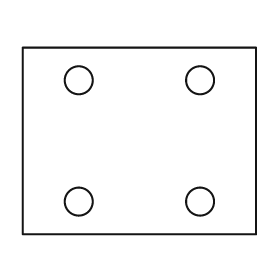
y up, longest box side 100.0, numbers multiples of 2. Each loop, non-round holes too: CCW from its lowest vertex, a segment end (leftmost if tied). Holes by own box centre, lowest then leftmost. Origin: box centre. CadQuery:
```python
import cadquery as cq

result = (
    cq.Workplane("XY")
    .moveTo(-50.0, -40.0)
    .lineTo(50.0, -40.0)
    .lineTo(50.0, 40.0)
    .lineTo(-50.0, 40.0)
    .close()
    .moveTo(-26.0, -26.0)
    .circle(6.0)
    .moveTo(26.0, -26.0)
    .circle(6.0)
    .moveTo(-26.0, 26.0)
    .circle(6.0)
    .moveTo(26.0, 26.0)
    .circle(6.0)
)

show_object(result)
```